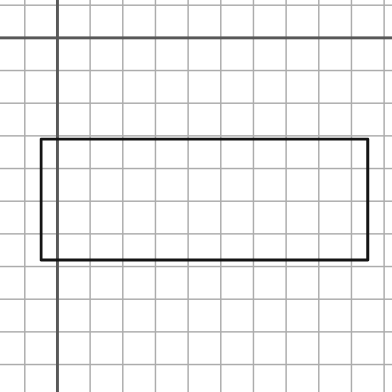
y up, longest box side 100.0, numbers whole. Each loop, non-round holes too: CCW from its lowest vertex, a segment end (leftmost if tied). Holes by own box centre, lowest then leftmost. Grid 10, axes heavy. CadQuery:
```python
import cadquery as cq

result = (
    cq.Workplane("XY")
    .moveTo(-5.0, -68.0)
    .lineTo(95.0, -68.0)
    .lineTo(95.0, -31.0)
    .lineTo(-5.0, -31.0)
    .close()
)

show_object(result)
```